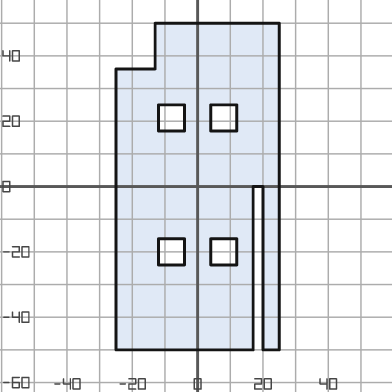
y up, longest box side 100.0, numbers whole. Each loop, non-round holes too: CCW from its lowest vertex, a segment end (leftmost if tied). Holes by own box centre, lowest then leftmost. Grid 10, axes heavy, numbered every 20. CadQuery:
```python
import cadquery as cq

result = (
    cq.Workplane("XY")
    .moveTo(-25.0, -50.0)
    .lineTo(17.0, -50.0)
    .lineTo(17.0, 0.0)
    .lineTo(20.0, 0.0)
    .lineTo(20.0, -50.0)
    .lineTo(25.0, -50.0)
    .lineTo(25.0, 50.0)
    .lineTo(-13.0, 50.0)
    .lineTo(-13.0, 36.0)
    .lineTo(-25.0, 36.0)
    .close()
    .moveTo(-12.0, -24.0)
    .lineTo(-4.0, -24.0)
    .lineTo(-4.0, -16.0)
    .lineTo(-12.0, -16.0)
    .close()
    .moveTo(4.0, -24.0)
    .lineTo(12.0, -24.0)
    .lineTo(12.0, -16.0)
    .lineTo(4.0, -16.0)
    .close()
    .moveTo(-12.0, 17.0)
    .lineTo(-4.0, 17.0)
    .lineTo(-4.0, 25.0)
    .lineTo(-12.0, 25.0)
    .close()
    .moveTo(4.0, 17.0)
    .lineTo(12.0, 17.0)
    .lineTo(12.0, 25.0)
    .lineTo(4.0, 25.0)
    .close()
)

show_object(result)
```